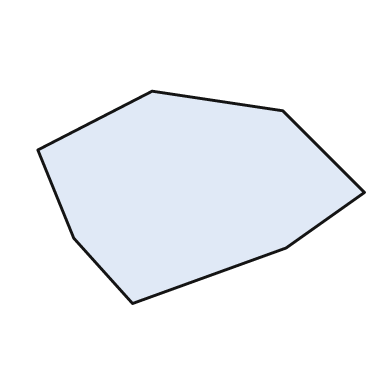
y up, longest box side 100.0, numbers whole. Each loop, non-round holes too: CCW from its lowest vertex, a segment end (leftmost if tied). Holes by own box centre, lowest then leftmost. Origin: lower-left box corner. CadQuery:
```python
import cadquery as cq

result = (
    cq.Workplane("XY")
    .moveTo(29.0, 0.0)
    .lineTo(76.0, 17.0)
    .lineTo(100.0, 34.0)
    .lineTo(75.0, 59.0)
    .lineTo(35.0, 65.0)
    .lineTo(0.0, 47.0)
    .lineTo(11.0, 20.0)
    .close()
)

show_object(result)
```